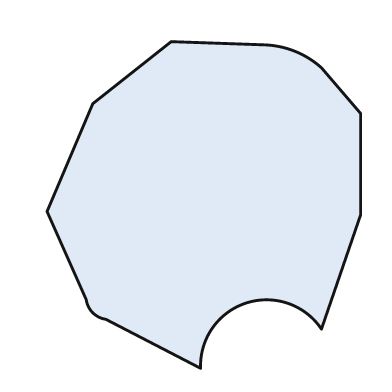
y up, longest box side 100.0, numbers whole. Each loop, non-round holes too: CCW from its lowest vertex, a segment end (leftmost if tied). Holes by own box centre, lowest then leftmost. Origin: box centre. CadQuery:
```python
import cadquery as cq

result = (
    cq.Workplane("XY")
    .moveTo(-1.0, -50.0)
    .threePointArc((13.0, -30.0), (36.0, -38.0))
    .lineTo(48.0, -3.0)
    .lineTo(48.0, 28.0)
    .lineTo(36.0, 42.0)
    .threePointArc((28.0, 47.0), (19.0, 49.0))
    .lineTo(-10.0, 50.0)
    .lineTo(-34.0, 31.0)
    .lineTo(-48.0, -2.0)
    .lineTo(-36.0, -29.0)
    .threePointArc((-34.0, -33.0), (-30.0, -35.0))
    .close()
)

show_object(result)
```